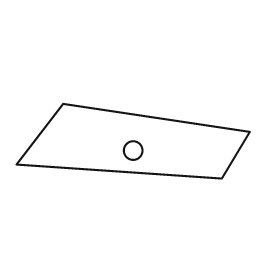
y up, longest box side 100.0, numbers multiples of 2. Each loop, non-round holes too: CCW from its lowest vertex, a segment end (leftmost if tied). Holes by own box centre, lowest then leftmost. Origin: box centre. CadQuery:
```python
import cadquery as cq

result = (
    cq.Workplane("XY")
    .moveTo(38.0, -16.0)
    .lineTo(50.0, 4.0)
    .lineTo(-30.0, 16.0)
    .lineTo(-50.0, -10.0)
    .close()
    .moveTo(0.0, -4.0)
    .circle(4.0)
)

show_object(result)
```